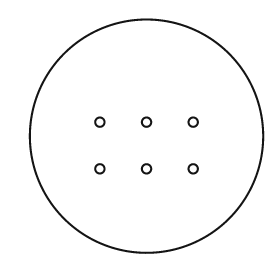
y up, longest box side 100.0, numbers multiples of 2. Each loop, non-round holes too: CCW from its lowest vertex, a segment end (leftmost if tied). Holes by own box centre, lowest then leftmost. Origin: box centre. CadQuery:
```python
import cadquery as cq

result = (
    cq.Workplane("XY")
    .moveTo(0.0, 0.0)
    .circle(50.0)
    .moveTo(-20.0, -14.0)
    .circle(2.0)
    .moveTo(0.0, -14.0)
    .circle(2.0)
    .moveTo(20.0, -14.0)
    .circle(2.0)
    .moveTo(-20.0, 6.0)
    .circle(2.0)
    .moveTo(0.0, 6.0)
    .circle(2.0)
    .moveTo(20.0, 6.0)
    .circle(2.0)
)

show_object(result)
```